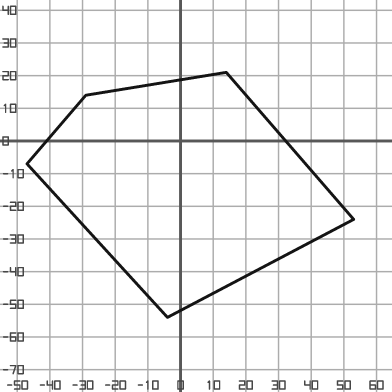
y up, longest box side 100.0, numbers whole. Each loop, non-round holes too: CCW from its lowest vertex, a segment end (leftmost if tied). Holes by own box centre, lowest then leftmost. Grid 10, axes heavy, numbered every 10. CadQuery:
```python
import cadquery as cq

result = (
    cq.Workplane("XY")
    .moveTo(-4.0, -54.0)
    .lineTo(53.0, -24.0)
    .lineTo(14.0, 21.0)
    .lineTo(-29.0, 14.0)
    .lineTo(-47.0, -7.0)
    .close()
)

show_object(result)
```